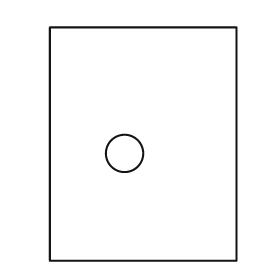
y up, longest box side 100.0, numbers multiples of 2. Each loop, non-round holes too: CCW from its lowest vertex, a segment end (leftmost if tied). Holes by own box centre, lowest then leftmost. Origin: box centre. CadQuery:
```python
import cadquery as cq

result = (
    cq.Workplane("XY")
    .moveTo(-40.0, -50.0)
    .lineTo(40.0, -50.0)
    .lineTo(40.0, 50.0)
    .lineTo(-40.0, 50.0)
    .close()
    .moveTo(-8.0, -4.0)
    .circle(8.0)
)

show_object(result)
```